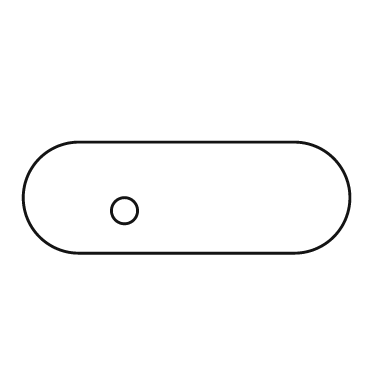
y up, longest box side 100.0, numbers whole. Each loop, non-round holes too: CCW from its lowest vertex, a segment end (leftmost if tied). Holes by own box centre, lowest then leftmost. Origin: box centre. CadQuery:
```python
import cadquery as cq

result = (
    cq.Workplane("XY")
    .moveTo(-33.0, -17.0)
    .lineTo(33.0, -17.0)
    .threePointArc((50.0, 0.0), (33.0, 17.0))
    .lineTo(-33.0, 17.0)
    .threePointArc((-50.0, 0.0), (-33.0, -17.0))
    .close()
    .moveTo(-19.0, -4.0)
    .circle(4.0)
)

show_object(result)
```